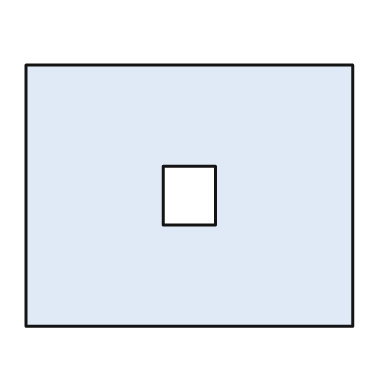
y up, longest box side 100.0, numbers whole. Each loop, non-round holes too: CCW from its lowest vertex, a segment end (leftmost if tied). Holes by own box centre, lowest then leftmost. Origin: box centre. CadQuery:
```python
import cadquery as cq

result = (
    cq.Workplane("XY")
    .moveTo(-50.0, -40.0)
    .lineTo(50.0, -40.0)
    .lineTo(50.0, 40.0)
    .lineTo(-50.0, 40.0)
    .close()
    .moveTo(-8.0, -9.0)
    .lineTo(8.0, -9.0)
    .lineTo(8.0, 9.0)
    .lineTo(-8.0, 9.0)
    .close()
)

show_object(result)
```